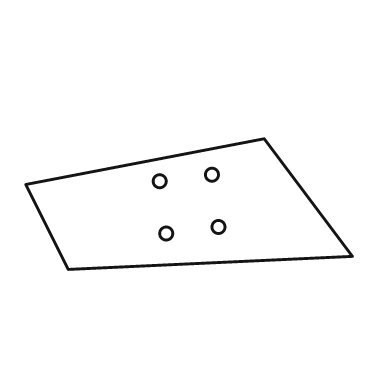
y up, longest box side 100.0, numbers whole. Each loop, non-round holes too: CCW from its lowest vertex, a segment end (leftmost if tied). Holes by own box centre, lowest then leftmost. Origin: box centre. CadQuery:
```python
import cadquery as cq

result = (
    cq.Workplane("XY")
    .moveTo(-37.0, -20.0)
    .lineTo(50.0, -16.0)
    .lineTo(23.0, 20.0)
    .lineTo(-50.0, 6.0)
    .close()
    .moveTo(-7.0, -9.0)
    .circle(2.0)
    .moveTo(9.0, -7.0)
    .circle(2.0)
    .moveTo(-9.0, 7.0)
    .circle(2.0)
    .moveTo(7.0, 9.0)
    .circle(2.0)
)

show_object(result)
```